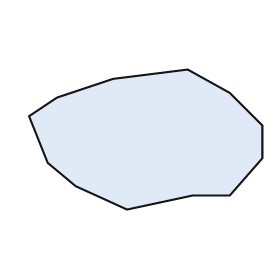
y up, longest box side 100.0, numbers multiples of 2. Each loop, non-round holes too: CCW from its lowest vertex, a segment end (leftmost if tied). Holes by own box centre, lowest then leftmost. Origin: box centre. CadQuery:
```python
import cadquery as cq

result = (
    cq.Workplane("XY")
    .moveTo(-8.0, -30.0)
    .lineTo(20.0, -24.0)
    .lineTo(36.0, -24.0)
    .lineTo(50.0, -8.0)
    .lineTo(50.0, 6.0)
    .lineTo(36.0, 20.0)
    .lineTo(18.0, 30.0)
    .lineTo(-14.0, 26.0)
    .lineTo(-38.0, 18.0)
    .lineTo(-50.0, 10.0)
    .lineTo(-42.0, -10.0)
    .lineTo(-30.0, -20.0)
    .close()
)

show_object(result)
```